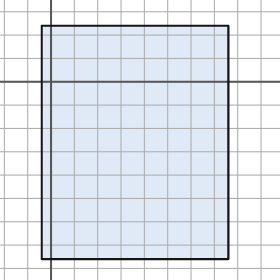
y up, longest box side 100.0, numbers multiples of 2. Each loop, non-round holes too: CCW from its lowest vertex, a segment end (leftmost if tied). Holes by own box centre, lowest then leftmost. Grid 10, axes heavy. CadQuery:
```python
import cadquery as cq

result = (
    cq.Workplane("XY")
    .moveTo(-4.0, -76.0)
    .lineTo(76.0, -76.0)
    .lineTo(76.0, 24.0)
    .lineTo(-4.0, 24.0)
    .close()
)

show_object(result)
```